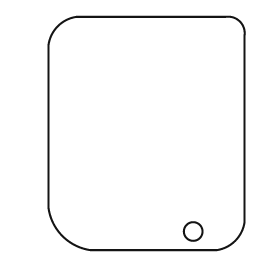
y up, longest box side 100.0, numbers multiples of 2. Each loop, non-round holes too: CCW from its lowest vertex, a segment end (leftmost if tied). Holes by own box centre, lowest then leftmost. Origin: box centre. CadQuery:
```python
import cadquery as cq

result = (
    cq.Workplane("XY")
    .moveTo(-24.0, -50.0)
    .lineTo(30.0, -50.0)
    .threePointArc((38.0, -46.0), (42.0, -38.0))
    .lineTo(42.0, 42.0)
    .threePointArc((40.0, 48.0), (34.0, 50.0))
    .lineTo(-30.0, 50.0)
    .threePointArc((-38.0, 46.0), (-42.0, 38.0))
    .lineTo(-42.0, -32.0)
    .threePointArc((-36.0, -44.0), (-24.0, -50.0))
    .close()
    .moveTo(20.0, -42.0)
    .circle(4.0)
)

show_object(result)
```